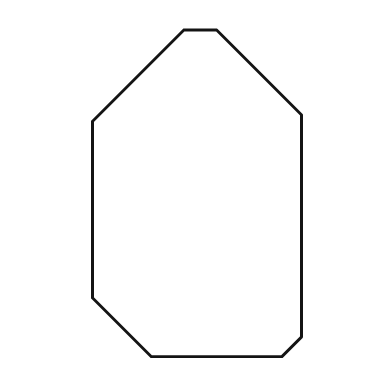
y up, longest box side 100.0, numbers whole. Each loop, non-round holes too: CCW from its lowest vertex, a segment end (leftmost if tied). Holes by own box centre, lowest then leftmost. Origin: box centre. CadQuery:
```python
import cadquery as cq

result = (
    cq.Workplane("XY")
    .moveTo(-14.0, -50.0)
    .lineTo(26.0, -50.0)
    .lineTo(32.0, -44.0)
    .lineTo(32.0, 24.0)
    .lineTo(6.0, 50.0)
    .lineTo(-4.0, 50.0)
    .lineTo(-32.0, 22.0)
    .lineTo(-32.0, -32.0)
    .close()
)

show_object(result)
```